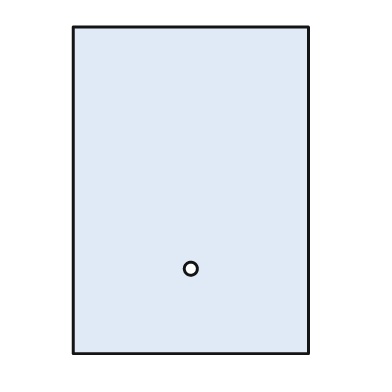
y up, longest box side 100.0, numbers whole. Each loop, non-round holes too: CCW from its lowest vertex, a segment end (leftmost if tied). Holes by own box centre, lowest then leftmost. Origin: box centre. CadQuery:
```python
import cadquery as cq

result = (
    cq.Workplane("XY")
    .moveTo(-36.0, -50.0)
    .lineTo(36.0, -50.0)
    .lineTo(36.0, 50.0)
    .lineTo(-36.0, 50.0)
    .close()
    .moveTo(0.0, -24.0)
    .circle(2.0)
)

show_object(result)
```